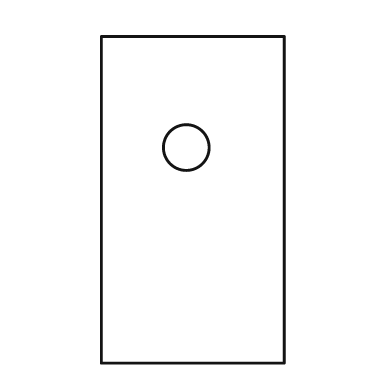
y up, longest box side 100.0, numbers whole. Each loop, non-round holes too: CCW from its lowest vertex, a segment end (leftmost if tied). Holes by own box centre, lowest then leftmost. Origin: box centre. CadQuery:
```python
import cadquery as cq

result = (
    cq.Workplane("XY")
    .moveTo(-28.0, -50.0)
    .lineTo(28.0, -50.0)
    .lineTo(28.0, 50.0)
    .lineTo(-28.0, 50.0)
    .close()
    .moveTo(-2.0, 16.0)
    .circle(7.0)
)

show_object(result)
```